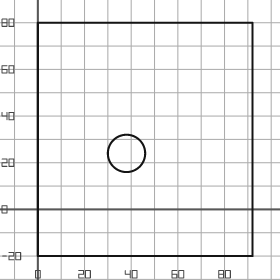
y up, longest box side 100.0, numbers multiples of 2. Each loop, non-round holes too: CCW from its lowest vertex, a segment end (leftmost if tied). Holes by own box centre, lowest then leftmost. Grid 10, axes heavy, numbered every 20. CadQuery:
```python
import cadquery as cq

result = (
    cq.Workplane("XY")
    .moveTo(0.0, -20.0)
    .lineTo(92.0, -20.0)
    .lineTo(92.0, 80.0)
    .lineTo(0.0, 80.0)
    .close()
    .moveTo(38.0, 24.0)
    .circle(8.0)
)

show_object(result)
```